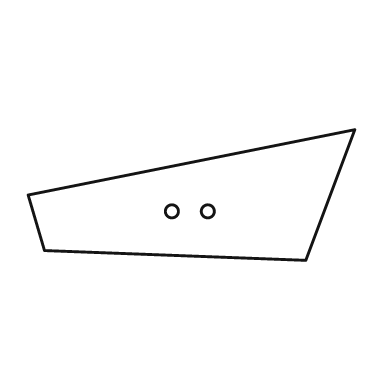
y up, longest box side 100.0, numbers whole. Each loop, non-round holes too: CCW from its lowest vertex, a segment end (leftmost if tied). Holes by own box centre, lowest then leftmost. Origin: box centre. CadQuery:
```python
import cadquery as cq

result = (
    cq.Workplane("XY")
    .moveTo(35.0, -20.0)
    .lineTo(50.0, 20.0)
    .lineTo(-50.0, 0.0)
    .lineTo(-45.0, -17.0)
    .close()
    .moveTo(-6.0, -5.0)
    .circle(2.0)
    .moveTo(5.0, -5.0)
    .circle(2.0)
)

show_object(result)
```